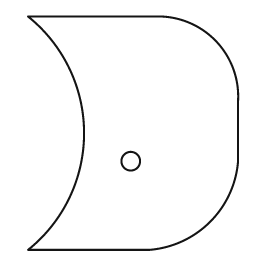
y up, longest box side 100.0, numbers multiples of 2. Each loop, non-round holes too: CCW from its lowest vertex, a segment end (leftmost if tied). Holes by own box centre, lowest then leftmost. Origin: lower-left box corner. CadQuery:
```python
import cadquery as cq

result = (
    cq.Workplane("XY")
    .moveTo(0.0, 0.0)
    .lineTo(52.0, 0.0)
    .threePointArc((78.0, 12.0), (90.0, 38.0))
    .lineTo(90.0, 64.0)
    .threePointArc((80.0, 90.0), (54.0, 100.0))
    .lineTo(0.0, 100.0)
    .threePointArc((24.0, 50.0), (0.0, 0.0))
    .close()
    .moveTo(44.0, 38.0)
    .circle(4.0)
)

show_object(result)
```